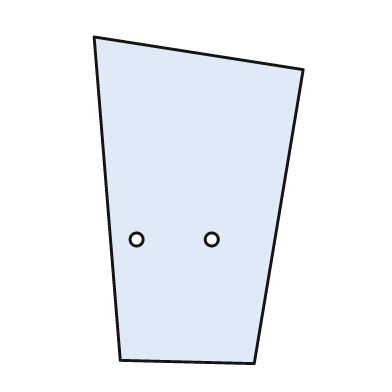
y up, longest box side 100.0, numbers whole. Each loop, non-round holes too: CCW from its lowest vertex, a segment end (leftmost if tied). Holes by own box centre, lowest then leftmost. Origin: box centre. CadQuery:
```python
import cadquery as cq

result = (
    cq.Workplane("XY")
    .moveTo(17.0, -50.0)
    .lineTo(32.0, 40.0)
    .lineTo(-32.0, 50.0)
    .lineTo(-24.0, -49.0)
    .close()
    .moveTo(-19.0, -12.0)
    .circle(2.0)
    .moveTo(4.0, -12.0)
    .circle(2.0)
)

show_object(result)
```